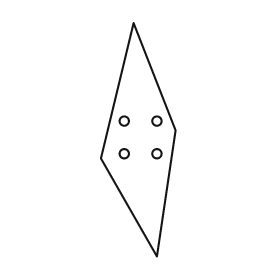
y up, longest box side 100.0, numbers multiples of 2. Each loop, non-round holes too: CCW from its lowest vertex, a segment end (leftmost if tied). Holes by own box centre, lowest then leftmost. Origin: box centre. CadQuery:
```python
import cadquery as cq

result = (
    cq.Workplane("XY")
    .moveTo(8.0, -50.0)
    .lineTo(16.0, 4.0)
    .lineTo(-2.0, 50.0)
    .lineTo(-16.0, -8.0)
    .close()
    .moveTo(-6.0, -6.0)
    .circle(2.0)
    .moveTo(8.0, -6.0)
    .circle(2.0)
    .moveTo(-6.0, 8.0)
    .circle(2.0)
    .moveTo(8.0, 8.0)
    .circle(2.0)
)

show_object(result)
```